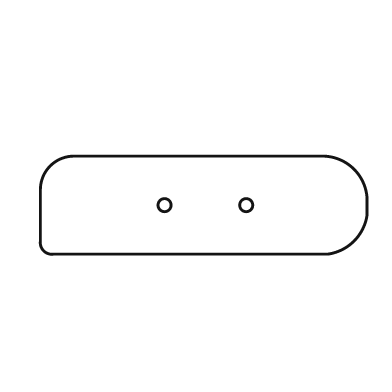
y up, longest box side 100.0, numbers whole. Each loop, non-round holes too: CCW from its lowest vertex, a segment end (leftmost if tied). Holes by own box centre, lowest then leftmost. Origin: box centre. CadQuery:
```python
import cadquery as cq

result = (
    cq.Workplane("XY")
    .moveTo(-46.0, -15.0)
    .lineTo(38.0, -15.0)
    .threePointArc((46.0, -11.0), (50.0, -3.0))
    .lineTo(50.0, 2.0)
    .threePointArc((46.0, 11.0), (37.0, 15.0))
    .lineTo(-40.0, 15.0)
    .threePointArc((-47.0, 12.0), (-50.0, 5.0))
    .lineTo(-50.0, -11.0)
    .threePointArc((-49.0, -14.0), (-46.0, -15.0))
    .close()
    .moveTo(-12.0, 0.0)
    .circle(2.0)
    .moveTo(13.0, 0.0)
    .circle(2.0)
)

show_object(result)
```